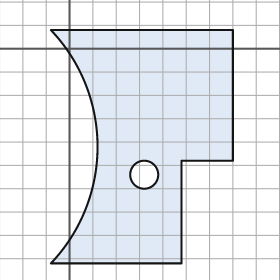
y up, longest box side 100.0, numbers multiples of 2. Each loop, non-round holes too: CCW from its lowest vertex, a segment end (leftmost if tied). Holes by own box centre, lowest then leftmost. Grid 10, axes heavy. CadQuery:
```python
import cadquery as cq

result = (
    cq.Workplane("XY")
    .moveTo(-8.0, -92.0)
    .lineTo(48.0, -92.0)
    .lineTo(48.0, -48.0)
    .lineTo(70.0, -48.0)
    .lineTo(70.0, 8.0)
    .lineTo(-8.0, 8.0)
    .threePointArc((12.0, -42.0), (-8.0, -92.0))
    .close()
    .moveTo(32.0, -54.0)
    .circle(6.0)
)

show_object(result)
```